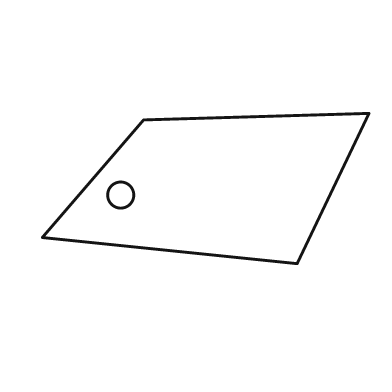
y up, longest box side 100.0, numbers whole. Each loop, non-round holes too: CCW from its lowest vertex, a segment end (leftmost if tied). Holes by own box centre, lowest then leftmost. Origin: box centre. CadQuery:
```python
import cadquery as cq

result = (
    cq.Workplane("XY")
    .moveTo(28.0, -23.0)
    .lineTo(50.0, 23.0)
    .lineTo(-19.0, 21.0)
    .lineTo(-50.0, -15.0)
    .close()
    .moveTo(-26.0, -2.0)
    .circle(4.0)
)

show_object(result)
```